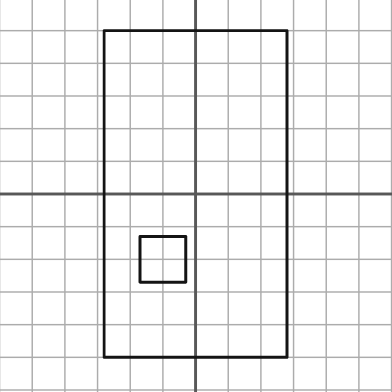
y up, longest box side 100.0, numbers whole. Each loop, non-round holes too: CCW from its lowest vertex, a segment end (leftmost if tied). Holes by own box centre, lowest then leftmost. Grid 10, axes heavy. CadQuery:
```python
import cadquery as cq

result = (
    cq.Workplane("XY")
    .moveTo(-28.0, -50.0)
    .lineTo(28.0, -50.0)
    .lineTo(28.0, 50.0)
    .lineTo(-28.0, 50.0)
    .close()
    .moveTo(-17.0, -27.0)
    .lineTo(-3.0, -27.0)
    .lineTo(-3.0, -13.0)
    .lineTo(-17.0, -13.0)
    .close()
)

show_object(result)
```